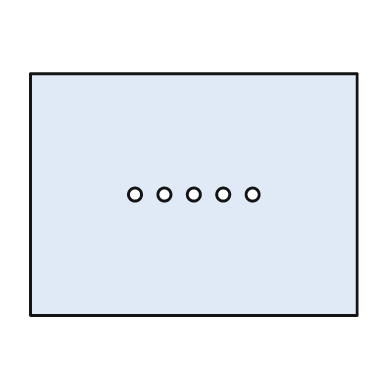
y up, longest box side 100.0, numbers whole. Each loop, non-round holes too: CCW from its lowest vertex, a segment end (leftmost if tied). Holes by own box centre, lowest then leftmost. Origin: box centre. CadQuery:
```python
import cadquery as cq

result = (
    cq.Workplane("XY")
    .moveTo(-50.0, -37.0)
    .lineTo(50.0, -37.0)
    .lineTo(50.0, 37.0)
    .lineTo(-50.0, 37.0)
    .close()
    .moveTo(-18.0, 0.0)
    .circle(2.0)
    .moveTo(-9.0, 0.0)
    .circle(2.0)
    .moveTo(0.0, 0.0)
    .circle(2.0)
    .moveTo(9.0, 0.0)
    .circle(2.0)
    .moveTo(18.0, 0.0)
    .circle(2.0)
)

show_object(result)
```